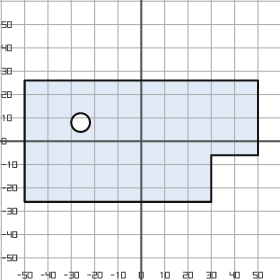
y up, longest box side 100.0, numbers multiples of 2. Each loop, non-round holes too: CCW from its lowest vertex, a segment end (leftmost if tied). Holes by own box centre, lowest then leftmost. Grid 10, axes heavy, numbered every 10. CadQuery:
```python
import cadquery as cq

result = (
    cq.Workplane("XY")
    .moveTo(-50.0, -26.0)
    .lineTo(30.0, -26.0)
    .lineTo(30.0, -6.0)
    .lineTo(50.0, -6.0)
    .lineTo(50.0, 26.0)
    .lineTo(-50.0, 26.0)
    .close()
    .moveTo(-26.0, 8.0)
    .circle(4.0)
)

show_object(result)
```